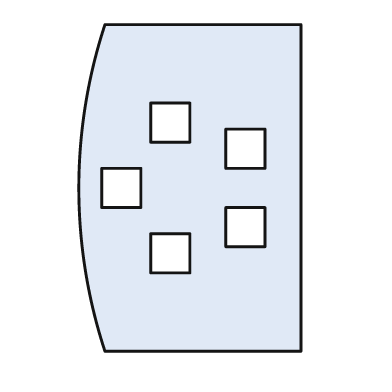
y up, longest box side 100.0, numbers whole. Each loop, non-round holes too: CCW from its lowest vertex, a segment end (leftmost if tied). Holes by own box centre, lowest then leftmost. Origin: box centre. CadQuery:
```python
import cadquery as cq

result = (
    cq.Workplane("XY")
    .moveTo(-26.0, -50.0)
    .lineTo(34.0, -50.0)
    .lineTo(34.0, 50.0)
    .lineTo(-26.0, 50.0)
    .threePointArc((-34.0, 0.0), (-26.0, -50.0))
    .close()
    .moveTo(-12.0, -26.0)
    .lineTo(0.0, -26.0)
    .lineTo(0.0, -14.0)
    .lineTo(-12.0, -14.0)
    .close()
    .moveTo(11.0, -18.0)
    .lineTo(23.0, -18.0)
    .lineTo(23.0, -6.0)
    .lineTo(11.0, -6.0)
    .close()
    .moveTo(-27.0, -6.0)
    .lineTo(-15.0, -6.0)
    .lineTo(-15.0, 6.0)
    .lineTo(-27.0, 6.0)
    .close()
    .moveTo(11.0, 6.0)
    .lineTo(23.0, 6.0)
    .lineTo(23.0, 18.0)
    .lineTo(11.0, 18.0)
    .close()
    .moveTo(-12.0, 14.0)
    .lineTo(0.0, 14.0)
    .lineTo(0.0, 26.0)
    .lineTo(-12.0, 26.0)
    .close()
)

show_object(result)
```